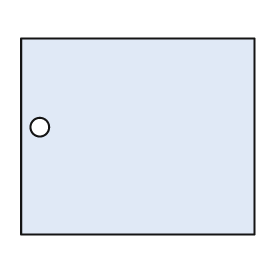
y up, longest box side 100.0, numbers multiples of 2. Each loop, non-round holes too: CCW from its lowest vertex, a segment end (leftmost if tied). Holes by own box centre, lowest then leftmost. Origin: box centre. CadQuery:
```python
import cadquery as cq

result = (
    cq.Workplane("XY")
    .moveTo(-50.0, -42.0)
    .lineTo(50.0, -42.0)
    .lineTo(50.0, 42.0)
    .lineTo(-50.0, 42.0)
    .close()
    .moveTo(-42.0, 4.0)
    .circle(4.0)
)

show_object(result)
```